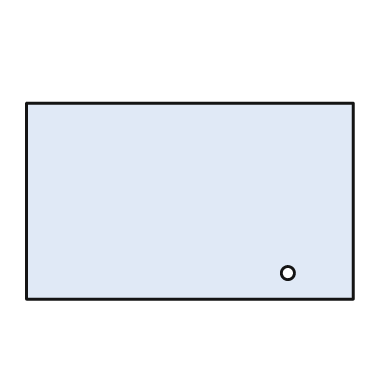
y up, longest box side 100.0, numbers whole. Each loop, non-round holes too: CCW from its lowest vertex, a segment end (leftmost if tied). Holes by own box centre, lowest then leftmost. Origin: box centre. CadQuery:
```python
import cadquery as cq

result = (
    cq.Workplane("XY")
    .moveTo(-50.0, -30.0)
    .lineTo(50.0, -30.0)
    .lineTo(50.0, 30.0)
    .lineTo(-50.0, 30.0)
    .close()
    .moveTo(30.0, -22.0)
    .circle(2.0)
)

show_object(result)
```